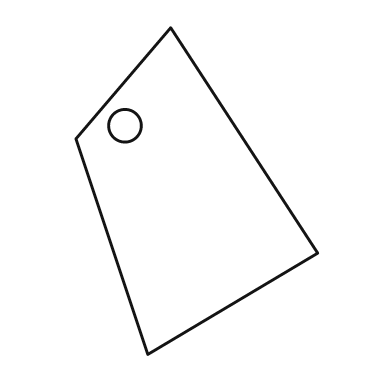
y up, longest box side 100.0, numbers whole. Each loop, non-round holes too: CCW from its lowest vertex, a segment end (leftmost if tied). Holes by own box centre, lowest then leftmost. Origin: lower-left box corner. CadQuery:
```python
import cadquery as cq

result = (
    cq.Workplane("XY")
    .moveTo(22.0, 0.0)
    .lineTo(74.0, 31.0)
    .lineTo(29.0, 100.0)
    .lineTo(0.0, 66.0)
    .close()
    .moveTo(15.0, 70.0)
    .circle(5.0)
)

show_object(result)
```